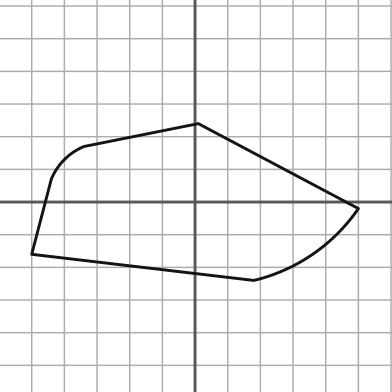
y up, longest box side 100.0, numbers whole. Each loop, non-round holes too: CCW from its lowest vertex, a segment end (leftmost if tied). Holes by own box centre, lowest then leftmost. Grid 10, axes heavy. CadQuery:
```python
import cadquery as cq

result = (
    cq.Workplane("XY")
    .moveTo(18.0, -24.0)
    .threePointArc((36.0, -16.0), (50.0, -2.0))
    .lineTo(1.0, 24.0)
    .lineTo(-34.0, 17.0)
    .threePointArc((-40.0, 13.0), (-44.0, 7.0))
    .lineTo(-50.0, -16.0)
    .close()
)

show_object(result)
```